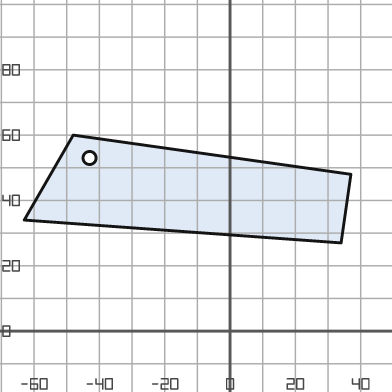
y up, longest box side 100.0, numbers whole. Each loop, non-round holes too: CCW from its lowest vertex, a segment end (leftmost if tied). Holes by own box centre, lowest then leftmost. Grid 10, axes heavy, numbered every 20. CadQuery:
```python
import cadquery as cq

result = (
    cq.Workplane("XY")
    .moveTo(34.0, 27.0)
    .lineTo(37.0, 48.0)
    .lineTo(-48.0, 60.0)
    .lineTo(-63.0, 34.0)
    .close()
    .moveTo(-43.0, 53.0)
    .circle(2.0)
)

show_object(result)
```